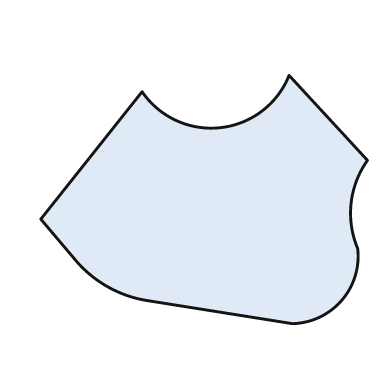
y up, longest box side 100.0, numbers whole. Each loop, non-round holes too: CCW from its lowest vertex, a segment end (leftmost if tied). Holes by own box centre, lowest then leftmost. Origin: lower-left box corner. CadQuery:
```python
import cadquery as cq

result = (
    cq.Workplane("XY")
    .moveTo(77.0, 0.0)
    .threePointArc((92.0, 7.0), (97.0, 23.0))
    .threePointArc((95.0, 37.0), (100.0, 50.0))
    .lineTo(76.0, 76.0)
    .threePointArc((55.0, 60.0), (31.0, 71.0))
    .lineTo(0.0, 32.0)
    .lineTo(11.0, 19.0)
    .threePointArc((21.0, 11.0), (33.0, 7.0))
    .close()
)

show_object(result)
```